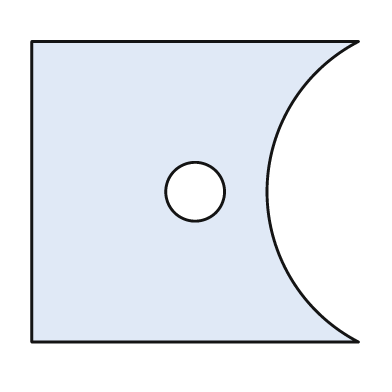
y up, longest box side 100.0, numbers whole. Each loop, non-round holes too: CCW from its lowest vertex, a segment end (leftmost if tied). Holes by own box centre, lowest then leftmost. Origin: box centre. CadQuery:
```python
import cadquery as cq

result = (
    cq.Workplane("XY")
    .moveTo(-50.0, -46.0)
    .lineTo(50.0, -46.0)
    .threePointArc((22.0, 0.0), (50.0, 46.0))
    .lineTo(-50.0, 46.0)
    .close()
    .moveTo(0.0, 0.0)
    .circle(9.0)
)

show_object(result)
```